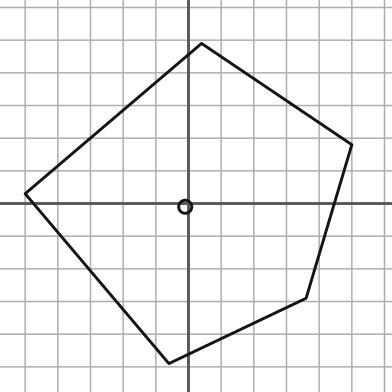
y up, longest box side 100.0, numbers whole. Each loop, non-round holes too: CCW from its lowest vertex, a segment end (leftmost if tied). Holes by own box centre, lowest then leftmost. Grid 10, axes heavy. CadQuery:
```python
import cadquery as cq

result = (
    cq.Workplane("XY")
    .moveTo(-6.0, -49.0)
    .lineTo(36.0, -29.0)
    .lineTo(50.0, 18.0)
    .lineTo(4.0, 49.0)
    .lineTo(-50.0, 3.0)
    .close()
    .moveTo(-1.0, -1.0)
    .circle(2.0)
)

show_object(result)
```